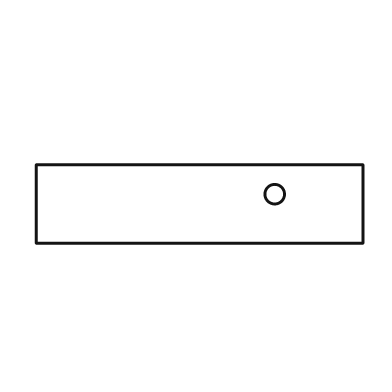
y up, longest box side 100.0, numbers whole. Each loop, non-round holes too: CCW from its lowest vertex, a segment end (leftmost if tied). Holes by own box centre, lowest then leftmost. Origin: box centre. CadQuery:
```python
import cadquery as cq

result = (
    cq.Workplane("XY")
    .moveTo(-50.0, -12.0)
    .lineTo(50.0, -12.0)
    .lineTo(50.0, 12.0)
    .lineTo(-50.0, 12.0)
    .close()
    .moveTo(23.0, 3.0)
    .circle(3.0)
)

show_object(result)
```